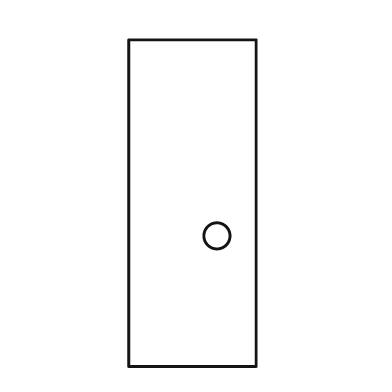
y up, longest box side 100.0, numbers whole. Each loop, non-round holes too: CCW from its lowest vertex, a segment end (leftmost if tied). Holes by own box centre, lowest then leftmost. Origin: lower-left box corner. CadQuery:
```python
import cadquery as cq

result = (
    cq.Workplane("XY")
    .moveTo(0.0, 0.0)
    .lineTo(39.0, 0.0)
    .lineTo(39.0, 100.0)
    .lineTo(0.0, 100.0)
    .close()
    .moveTo(27.0, 40.0)
    .circle(4.0)
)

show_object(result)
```